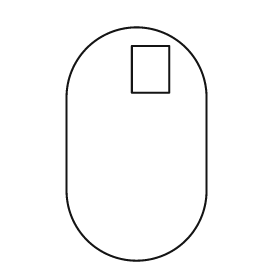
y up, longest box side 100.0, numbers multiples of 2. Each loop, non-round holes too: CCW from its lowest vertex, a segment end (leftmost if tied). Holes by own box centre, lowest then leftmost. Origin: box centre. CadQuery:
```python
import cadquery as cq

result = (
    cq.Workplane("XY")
    .moveTo(-30.0, -20.0)
    .threePointArc((0.0, -50.0), (30.0, -20.0))
    .lineTo(30.0, 20.0)
    .threePointArc((0.0, 50.0), (-30.0, 20.0))
    .close()
    .moveTo(-2.0, 22.0)
    .lineTo(14.0, 22.0)
    .lineTo(14.0, 42.0)
    .lineTo(-2.0, 42.0)
    .close()
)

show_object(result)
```